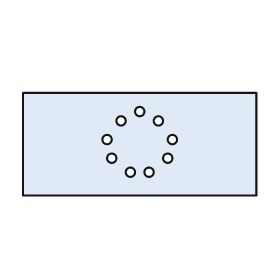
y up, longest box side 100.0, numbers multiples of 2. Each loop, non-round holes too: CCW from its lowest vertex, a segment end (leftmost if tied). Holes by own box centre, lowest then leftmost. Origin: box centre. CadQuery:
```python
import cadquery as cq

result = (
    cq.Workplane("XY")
    .moveTo(-50.0, -22.0)
    .lineTo(50.0, -22.0)
    .lineTo(50.0, 22.0)
    .lineTo(-50.0, 22.0)
    .close()
    .moveTo(-4.0, -12.0)
    .circle(2.0)
    .moveTo(4.0, -12.0)
    .circle(2.0)
    .moveTo(-12.0, -6.0)
    .circle(2.0)
    .moveTo(12.0, -6.0)
    .circle(2.0)
    .moveTo(-14.0, 2.0)
    .circle(2.0)
    .moveTo(14.0, 2.0)
    .circle(2.0)
    .moveTo(-8.0, 10.0)
    .circle(2.0)
    .moveTo(8.0, 10.0)
    .circle(2.0)
    .moveTo(0.0, 14.0)
    .circle(2.0)
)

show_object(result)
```